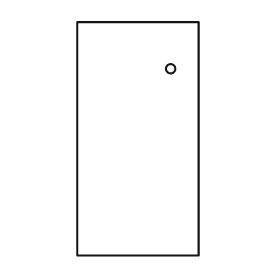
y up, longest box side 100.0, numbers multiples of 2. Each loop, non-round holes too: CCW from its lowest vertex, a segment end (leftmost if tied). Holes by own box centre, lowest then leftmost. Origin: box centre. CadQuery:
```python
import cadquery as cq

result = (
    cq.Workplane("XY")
    .moveTo(-26.0, -50.0)
    .lineTo(26.0, -50.0)
    .lineTo(26.0, 50.0)
    .lineTo(-26.0, 50.0)
    .close()
    .moveTo(14.0, 30.0)
    .circle(2.0)
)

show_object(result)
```